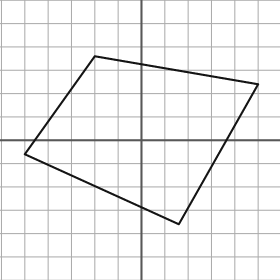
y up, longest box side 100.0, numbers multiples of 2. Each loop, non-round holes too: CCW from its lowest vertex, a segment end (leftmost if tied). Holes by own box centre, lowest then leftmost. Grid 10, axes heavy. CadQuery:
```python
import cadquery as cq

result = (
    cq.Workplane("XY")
    .moveTo(16.0, -36.0)
    .lineTo(50.0, 24.0)
    .lineTo(-20.0, 36.0)
    .lineTo(-50.0, -6.0)
    .close()
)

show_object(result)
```